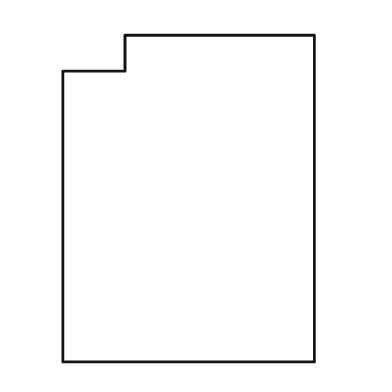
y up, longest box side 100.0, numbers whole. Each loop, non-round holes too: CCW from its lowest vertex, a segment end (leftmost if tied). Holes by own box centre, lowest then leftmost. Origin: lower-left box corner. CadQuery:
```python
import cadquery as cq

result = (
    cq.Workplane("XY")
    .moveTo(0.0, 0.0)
    .lineTo(77.0, 0.0)
    .lineTo(77.0, 100.0)
    .lineTo(19.0, 100.0)
    .lineTo(19.0, 89.0)
    .lineTo(0.0, 89.0)
    .close()
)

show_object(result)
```